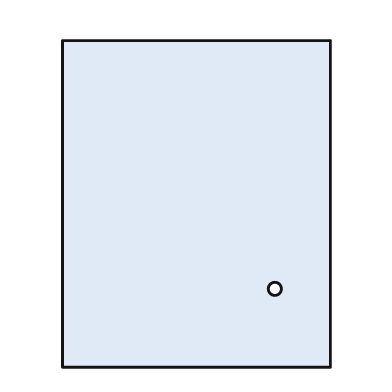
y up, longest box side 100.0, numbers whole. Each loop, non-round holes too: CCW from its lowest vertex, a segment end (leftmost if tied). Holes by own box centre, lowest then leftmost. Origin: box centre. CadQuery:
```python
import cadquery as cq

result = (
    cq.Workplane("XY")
    .moveTo(-41.0, -50.0)
    .lineTo(41.0, -50.0)
    .lineTo(41.0, 50.0)
    .lineTo(-41.0, 50.0)
    .close()
    .moveTo(24.0, -26.0)
    .circle(2.0)
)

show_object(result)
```